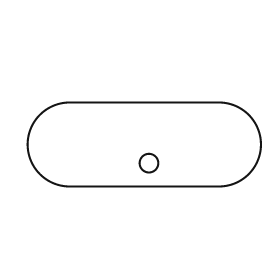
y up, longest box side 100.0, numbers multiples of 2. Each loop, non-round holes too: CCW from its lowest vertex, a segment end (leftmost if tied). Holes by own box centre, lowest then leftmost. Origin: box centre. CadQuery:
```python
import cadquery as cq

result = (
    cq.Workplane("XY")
    .moveTo(-32.0, -18.0)
    .lineTo(32.0, -18.0)
    .threePointArc((50.0, 0.0), (32.0, 18.0))
    .lineTo(-32.0, 18.0)
    .threePointArc((-50.0, 0.0), (-32.0, -18.0))
    .close()
    .moveTo(2.0, -8.0)
    .circle(4.0)
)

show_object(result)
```